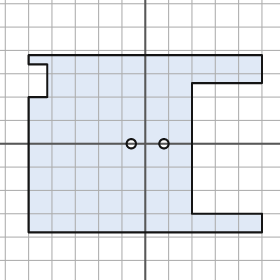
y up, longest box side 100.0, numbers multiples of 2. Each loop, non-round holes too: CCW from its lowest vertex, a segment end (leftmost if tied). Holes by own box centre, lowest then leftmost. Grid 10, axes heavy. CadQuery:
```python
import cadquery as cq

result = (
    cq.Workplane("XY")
    .moveTo(-50.0, -38.0)
    .lineTo(50.0, -38.0)
    .lineTo(50.0, -30.0)
    .lineTo(20.0, -30.0)
    .lineTo(20.0, 26.0)
    .lineTo(50.0, 26.0)
    .lineTo(50.0, 38.0)
    .lineTo(-50.0, 38.0)
    .lineTo(-50.0, 34.0)
    .lineTo(-42.0, 34.0)
    .lineTo(-42.0, 20.0)
    .lineTo(-50.0, 20.0)
    .close()
    .moveTo(-6.0, 0.0)
    .circle(2.0)
    .moveTo(8.0, 0.0)
    .circle(2.0)
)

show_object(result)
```